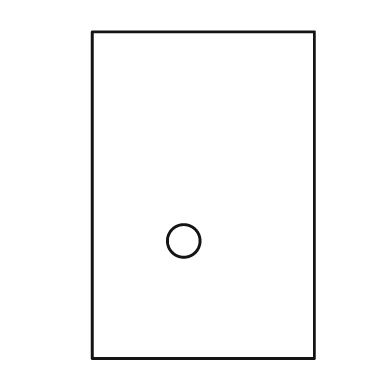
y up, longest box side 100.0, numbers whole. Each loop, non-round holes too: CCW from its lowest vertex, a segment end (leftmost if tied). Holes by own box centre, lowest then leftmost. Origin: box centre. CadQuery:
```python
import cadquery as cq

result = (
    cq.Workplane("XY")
    .moveTo(-34.0, -50.0)
    .lineTo(34.0, -50.0)
    .lineTo(34.0, 50.0)
    .lineTo(-34.0, 50.0)
    .close()
    .moveTo(-6.0, -14.0)
    .circle(5.0)
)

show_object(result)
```